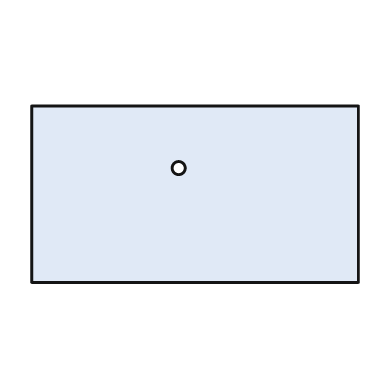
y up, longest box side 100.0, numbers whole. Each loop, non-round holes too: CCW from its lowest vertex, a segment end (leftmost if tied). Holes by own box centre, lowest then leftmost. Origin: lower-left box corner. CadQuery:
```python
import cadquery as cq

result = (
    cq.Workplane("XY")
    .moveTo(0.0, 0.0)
    .lineTo(100.0, 0.0)
    .lineTo(100.0, 54.0)
    .lineTo(0.0, 54.0)
    .close()
    .moveTo(45.0, 35.0)
    .circle(2.0)
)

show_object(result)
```